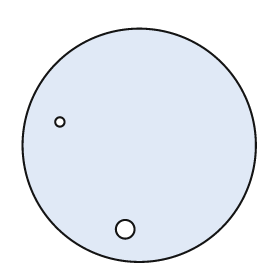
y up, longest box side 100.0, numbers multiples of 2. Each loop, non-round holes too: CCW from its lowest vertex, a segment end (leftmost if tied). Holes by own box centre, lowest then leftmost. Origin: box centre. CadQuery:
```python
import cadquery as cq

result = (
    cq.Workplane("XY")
    .moveTo(0.0, 0.0)
    .circle(50.0)
    .moveTo(-6.0, -36.0)
    .circle(4.0)
    .moveTo(-34.0, 10.0)
    .circle(2.0)
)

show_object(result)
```